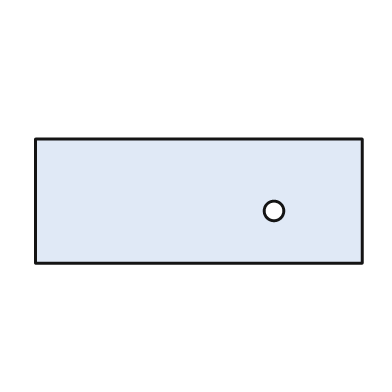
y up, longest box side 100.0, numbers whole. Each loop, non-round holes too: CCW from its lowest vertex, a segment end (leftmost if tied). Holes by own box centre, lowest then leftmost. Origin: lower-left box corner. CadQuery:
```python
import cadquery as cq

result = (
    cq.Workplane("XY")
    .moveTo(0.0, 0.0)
    .lineTo(100.0, 0.0)
    .lineTo(100.0, 38.0)
    .lineTo(0.0, 38.0)
    .close()
    .moveTo(73.0, 16.0)
    .circle(3.0)
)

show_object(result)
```